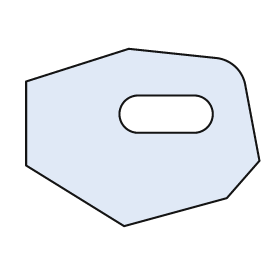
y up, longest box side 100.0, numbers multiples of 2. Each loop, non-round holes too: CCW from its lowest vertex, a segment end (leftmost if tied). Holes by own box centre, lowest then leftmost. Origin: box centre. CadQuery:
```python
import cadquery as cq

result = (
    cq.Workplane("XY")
    .moveTo(-8.0, -38.0)
    .lineTo(36.0, -26.0)
    .lineTo(50.0, -10.0)
    .lineTo(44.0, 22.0)
    .threePointArc((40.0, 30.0), (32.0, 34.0))
    .lineTo(-6.0, 38.0)
    .lineTo(-50.0, 24.0)
    .lineTo(-50.0, -12.0)
    .close()
    .moveTo(-2.0, 2.0)
    .lineTo(22.0, 2.0)
    .threePointArc((30.0, 10.0), (22.0, 18.0))
    .lineTo(-2.0, 18.0)
    .threePointArc((-10.0, 10.0), (-2.0, 2.0))
    .close()
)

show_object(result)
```